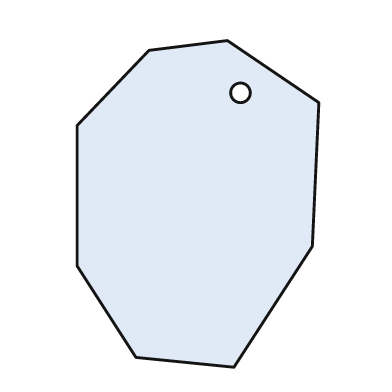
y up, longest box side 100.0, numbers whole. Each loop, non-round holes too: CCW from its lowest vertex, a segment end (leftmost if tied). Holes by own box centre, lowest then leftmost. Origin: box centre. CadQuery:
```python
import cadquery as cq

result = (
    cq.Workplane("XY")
    .moveTo(11.0, -50.0)
    .lineTo(35.0, -13.0)
    .lineTo(37.0, 31.0)
    .lineTo(9.0, 50.0)
    .lineTo(-15.0, 47.0)
    .lineTo(-37.0, 24.0)
    .lineTo(-37.0, -19.0)
    .lineTo(-19.0, -47.0)
    .close()
    .moveTo(13.0, 34.0)
    .circle(3.0)
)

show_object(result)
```